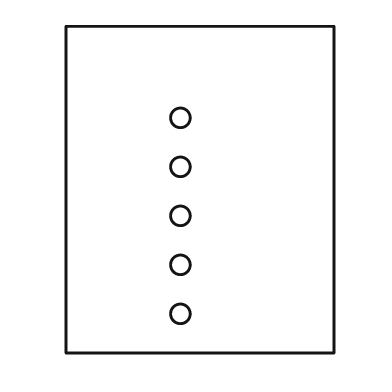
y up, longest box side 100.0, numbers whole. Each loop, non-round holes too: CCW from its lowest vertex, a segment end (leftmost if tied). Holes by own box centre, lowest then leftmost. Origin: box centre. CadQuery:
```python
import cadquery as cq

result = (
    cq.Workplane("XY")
    .moveTo(-41.0, -50.0)
    .lineTo(41.0, -50.0)
    .lineTo(41.0, 50.0)
    .lineTo(-41.0, 50.0)
    .close()
    .moveTo(-6.0, -38.0)
    .circle(3.0)
    .moveTo(-6.0, -23.0)
    .circle(3.0)
    .moveTo(-6.0, -8.0)
    .circle(3.0)
    .moveTo(-6.0, 7.0)
    .circle(3.0)
    .moveTo(-6.0, 22.0)
    .circle(3.0)
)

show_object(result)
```